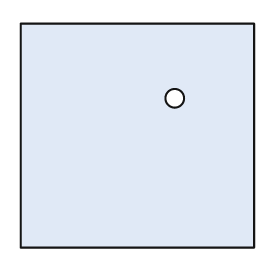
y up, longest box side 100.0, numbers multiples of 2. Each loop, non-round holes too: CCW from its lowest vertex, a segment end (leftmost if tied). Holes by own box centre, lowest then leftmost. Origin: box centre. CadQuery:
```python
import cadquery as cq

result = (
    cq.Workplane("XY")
    .moveTo(-50.0, -48.0)
    .lineTo(50.0, -48.0)
    .lineTo(50.0, 48.0)
    .lineTo(-50.0, 48.0)
    .close()
    .moveTo(16.0, 16.0)
    .circle(4.0)
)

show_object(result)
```